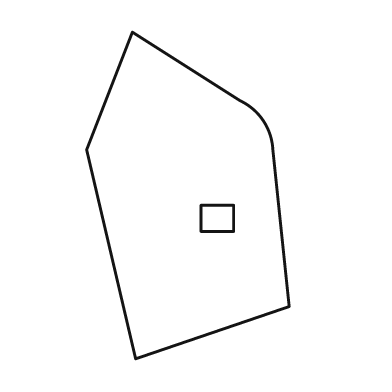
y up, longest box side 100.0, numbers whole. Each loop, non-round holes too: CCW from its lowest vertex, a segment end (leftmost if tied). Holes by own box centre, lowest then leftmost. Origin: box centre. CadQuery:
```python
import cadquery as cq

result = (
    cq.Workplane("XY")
    .moveTo(-16.0, -50.0)
    .lineTo(31.0, -34.0)
    .lineTo(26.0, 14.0)
    .threePointArc((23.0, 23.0), (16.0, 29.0))
    .lineTo(-17.0, 50.0)
    .lineTo(-31.0, 14.0)
    .close()
    .moveTo(4.0, -11.0)
    .lineTo(14.0, -11.0)
    .lineTo(14.0, -3.0)
    .lineTo(4.0, -3.0)
    .close()
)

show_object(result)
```